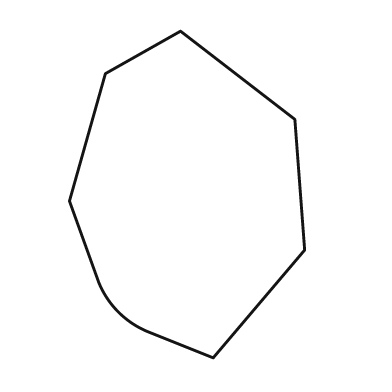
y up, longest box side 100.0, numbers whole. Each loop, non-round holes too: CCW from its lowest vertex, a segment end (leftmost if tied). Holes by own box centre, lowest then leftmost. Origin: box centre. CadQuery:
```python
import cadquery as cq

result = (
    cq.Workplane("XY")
    .moveTo(8.0, -50.0)
    .lineTo(36.0, -17.0)
    .lineTo(33.0, 23.0)
    .lineTo(-2.0, 50.0)
    .lineTo(-25.0, 37.0)
    .lineTo(-36.0, -2.0)
    .lineTo(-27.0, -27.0)
    .threePointArc((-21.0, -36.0), (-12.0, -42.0))
    .close()
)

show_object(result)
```